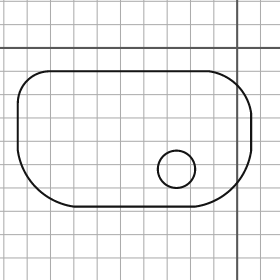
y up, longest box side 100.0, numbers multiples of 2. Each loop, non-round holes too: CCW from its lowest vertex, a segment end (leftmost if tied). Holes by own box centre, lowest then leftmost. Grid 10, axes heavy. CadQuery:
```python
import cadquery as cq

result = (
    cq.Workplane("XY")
    .moveTo(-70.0, -68.0)
    .lineTo(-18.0, -68.0)
    .threePointArc((-2.0, -60.0), (6.0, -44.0))
    .lineTo(6.0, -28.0)
    .threePointArc((0.0, -16.0), (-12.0, -10.0))
    .lineTo(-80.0, -10.0)
    .threePointArc((-90.0, -14.0), (-94.0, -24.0))
    .lineTo(-94.0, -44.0)
    .threePointArc((-86.0, -60.0), (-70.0, -68.0))
    .close()
    .moveTo(-26.0, -52.0)
    .circle(8.0)
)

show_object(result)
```